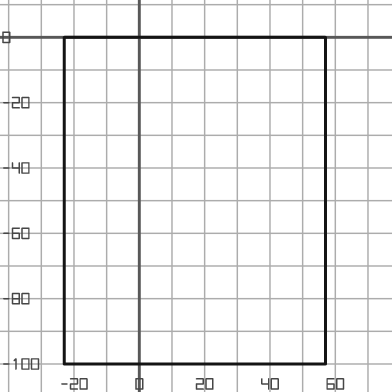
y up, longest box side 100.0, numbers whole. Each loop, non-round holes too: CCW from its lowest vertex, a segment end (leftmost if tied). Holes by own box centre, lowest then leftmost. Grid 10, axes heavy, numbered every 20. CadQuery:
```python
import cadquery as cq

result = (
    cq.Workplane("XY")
    .moveTo(-23.0, -100.0)
    .lineTo(57.0, -100.0)
    .lineTo(57.0, 0.0)
    .lineTo(-23.0, 0.0)
    .close()
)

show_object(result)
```